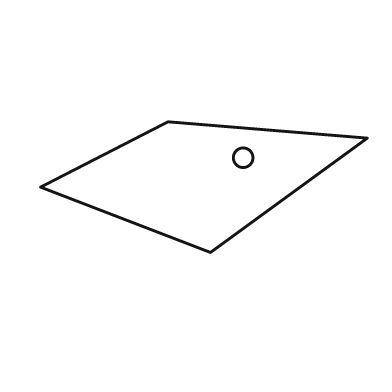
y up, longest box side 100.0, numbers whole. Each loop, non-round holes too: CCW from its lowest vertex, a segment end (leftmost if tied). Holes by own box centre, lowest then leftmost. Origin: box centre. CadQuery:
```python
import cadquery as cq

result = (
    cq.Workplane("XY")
    .moveTo(2.0, -20.0)
    .lineTo(50.0, 15.0)
    .lineTo(-11.0, 20.0)
    .lineTo(-50.0, 0.0)
    .close()
    .moveTo(12.0, 9.0)
    .circle(3.0)
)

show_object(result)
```